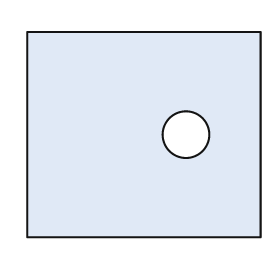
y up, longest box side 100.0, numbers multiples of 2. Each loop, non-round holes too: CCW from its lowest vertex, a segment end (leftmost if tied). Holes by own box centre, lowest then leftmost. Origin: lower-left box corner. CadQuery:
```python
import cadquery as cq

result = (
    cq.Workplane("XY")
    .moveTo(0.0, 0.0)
    .lineTo(100.0, 0.0)
    .lineTo(100.0, 88.0)
    .lineTo(0.0, 88.0)
    .close()
    .moveTo(68.0, 44.0)
    .circle(10.0)
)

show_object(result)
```